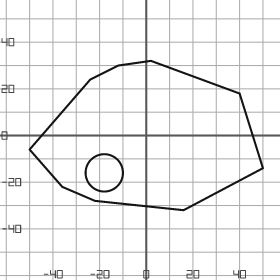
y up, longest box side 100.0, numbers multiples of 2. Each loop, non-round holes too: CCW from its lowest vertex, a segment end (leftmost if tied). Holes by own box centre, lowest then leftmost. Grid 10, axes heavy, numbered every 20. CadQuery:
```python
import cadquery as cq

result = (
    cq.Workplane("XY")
    .moveTo(16.0, -32.0)
    .lineTo(50.0, -14.0)
    .lineTo(40.0, 18.0)
    .lineTo(2.0, 32.0)
    .lineTo(-12.0, 30.0)
    .lineTo(-24.0, 24.0)
    .lineTo(-50.0, -6.0)
    .lineTo(-36.0, -22.0)
    .lineTo(-22.0, -28.0)
    .close()
    .moveTo(-18.0, -16.0)
    .circle(8.0)
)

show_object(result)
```